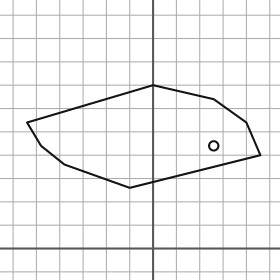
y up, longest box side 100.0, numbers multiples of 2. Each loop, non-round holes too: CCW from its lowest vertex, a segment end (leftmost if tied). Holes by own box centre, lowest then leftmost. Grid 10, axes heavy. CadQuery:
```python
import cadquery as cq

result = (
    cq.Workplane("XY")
    .moveTo(-10.0, 26.0)
    .lineTo(46.0, 40.0)
    .lineTo(40.0, 54.0)
    .lineTo(26.0, 64.0)
    .lineTo(0.0, 70.0)
    .lineTo(-54.0, 54.0)
    .lineTo(-48.0, 44.0)
    .lineTo(-38.0, 36.0)
    .close()
    .moveTo(26.0, 44.0)
    .circle(2.0)
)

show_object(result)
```